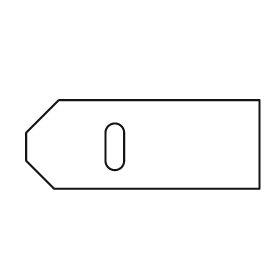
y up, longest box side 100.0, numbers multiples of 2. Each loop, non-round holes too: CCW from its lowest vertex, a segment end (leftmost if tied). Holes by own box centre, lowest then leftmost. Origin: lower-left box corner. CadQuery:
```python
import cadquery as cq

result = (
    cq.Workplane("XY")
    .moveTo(12.0, 0.0)
    .lineTo(100.0, 0.0)
    .lineTo(100.0, 38.0)
    .lineTo(14.0, 38.0)
    .lineTo(0.0, 24.0)
    .lineTo(0.0, 12.0)
    .close()
    .moveTo(34.0, 12.0)
    .threePointArc((38.0, 8.0), (42.0, 12.0))
    .lineTo(42.0, 24.0)
    .threePointArc((38.0, 28.0), (34.0, 24.0))
    .close()
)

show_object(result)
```